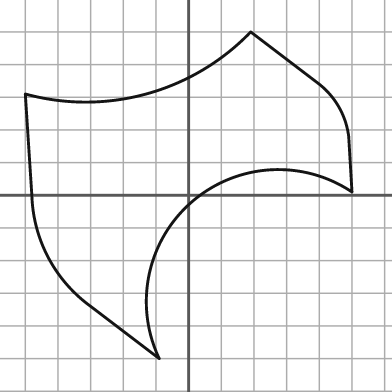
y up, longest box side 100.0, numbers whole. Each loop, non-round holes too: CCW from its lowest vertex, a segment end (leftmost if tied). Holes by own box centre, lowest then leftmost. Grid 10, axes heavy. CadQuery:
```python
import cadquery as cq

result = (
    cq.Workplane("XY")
    .moveTo(-9.0, -50.0)
    .threePointArc((1.0, -2.0), (50.0, 1.0))
    .lineTo(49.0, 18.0)
    .threePointArc((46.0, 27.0), (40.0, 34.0))
    .lineTo(19.0, 50.0)
    .threePointArc((-13.0, 31.0), (-50.0, 31.0))
    .lineTo(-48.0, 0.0)
    .threePointArc((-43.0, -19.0), (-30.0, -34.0))
    .close()
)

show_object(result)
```